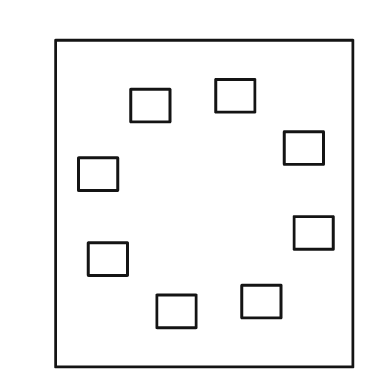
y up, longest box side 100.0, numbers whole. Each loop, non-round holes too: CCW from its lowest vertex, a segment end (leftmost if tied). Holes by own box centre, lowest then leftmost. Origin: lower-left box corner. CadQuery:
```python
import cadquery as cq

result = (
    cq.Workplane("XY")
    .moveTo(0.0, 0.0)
    .lineTo(91.0, 0.0)
    .lineTo(91.0, 100.0)
    .lineTo(0.0, 100.0)
    .close()
    .moveTo(31.0, 12.0)
    .lineTo(43.0, 12.0)
    .lineTo(43.0, 22.0)
    .lineTo(31.0, 22.0)
    .close()
    .moveTo(57.0, 15.0)
    .lineTo(69.0, 15.0)
    .lineTo(69.0, 25.0)
    .lineTo(57.0, 25.0)
    .close()
    .moveTo(10.0, 28.0)
    .lineTo(22.0, 28.0)
    .lineTo(22.0, 38.0)
    .lineTo(10.0, 38.0)
    .close()
    .moveTo(73.0, 36.0)
    .lineTo(85.0, 36.0)
    .lineTo(85.0, 46.0)
    .lineTo(73.0, 46.0)
    .close()
    .moveTo(7.0, 54.0)
    .lineTo(19.0, 54.0)
    .lineTo(19.0, 64.0)
    .lineTo(7.0, 64.0)
    .close()
    .moveTo(70.0, 62.0)
    .lineTo(82.0, 62.0)
    .lineTo(82.0, 72.0)
    .lineTo(70.0, 72.0)
    .close()
    .moveTo(23.0, 75.0)
    .lineTo(35.0, 75.0)
    .lineTo(35.0, 85.0)
    .lineTo(23.0, 85.0)
    .close()
    .moveTo(49.0, 78.0)
    .lineTo(61.0, 78.0)
    .lineTo(61.0, 88.0)
    .lineTo(49.0, 88.0)
    .close()
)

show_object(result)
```